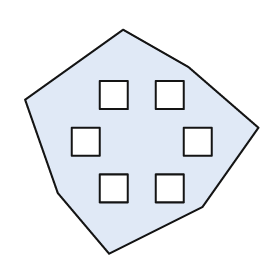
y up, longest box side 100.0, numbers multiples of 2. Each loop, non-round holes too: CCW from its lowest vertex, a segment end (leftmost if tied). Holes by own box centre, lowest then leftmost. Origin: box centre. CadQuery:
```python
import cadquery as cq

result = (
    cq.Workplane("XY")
    .moveTo(-14.0, -48.0)
    .lineTo(26.0, -28.0)
    .lineTo(50.0, 6.0)
    .lineTo(20.0, 32.0)
    .lineTo(-8.0, 48.0)
    .lineTo(-50.0, 18.0)
    .lineTo(-36.0, -22.0)
    .close()
    .moveTo(-18.0, -26.0)
    .lineTo(-6.0, -26.0)
    .lineTo(-6.0, -14.0)
    .lineTo(-18.0, -14.0)
    .close()
    .moveTo(6.0, -26.0)
    .lineTo(18.0, -26.0)
    .lineTo(18.0, -14.0)
    .lineTo(6.0, -14.0)
    .close()
    .moveTo(-30.0, -6.0)
    .lineTo(-18.0, -6.0)
    .lineTo(-18.0, 6.0)
    .lineTo(-30.0, 6.0)
    .close()
    .moveTo(18.0, -6.0)
    .lineTo(30.0, -6.0)
    .lineTo(30.0, 6.0)
    .lineTo(18.0, 6.0)
    .close()
    .moveTo(-18.0, 14.0)
    .lineTo(-6.0, 14.0)
    .lineTo(-6.0, 26.0)
    .lineTo(-18.0, 26.0)
    .close()
    .moveTo(6.0, 14.0)
    .lineTo(18.0, 14.0)
    .lineTo(18.0, 26.0)
    .lineTo(6.0, 26.0)
    .close()
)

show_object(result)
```